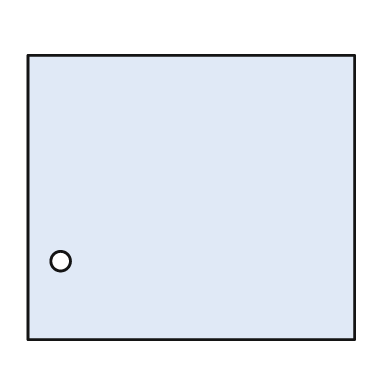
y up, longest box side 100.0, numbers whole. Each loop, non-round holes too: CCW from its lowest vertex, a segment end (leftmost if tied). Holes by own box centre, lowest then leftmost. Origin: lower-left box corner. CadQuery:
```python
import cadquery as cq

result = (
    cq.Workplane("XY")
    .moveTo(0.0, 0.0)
    .lineTo(100.0, 0.0)
    .lineTo(100.0, 87.0)
    .lineTo(0.0, 87.0)
    .close()
    .moveTo(10.0, 24.0)
    .circle(3.0)
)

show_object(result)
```